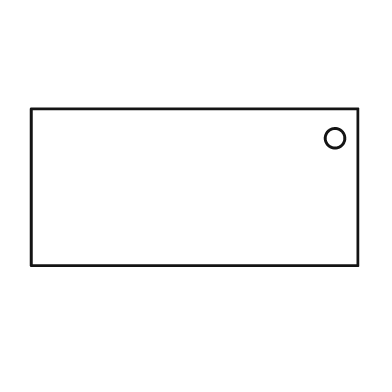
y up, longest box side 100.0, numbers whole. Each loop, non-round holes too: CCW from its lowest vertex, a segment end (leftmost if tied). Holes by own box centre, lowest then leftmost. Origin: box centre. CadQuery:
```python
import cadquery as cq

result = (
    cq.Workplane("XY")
    .moveTo(-50.0, -24.0)
    .lineTo(50.0, -24.0)
    .lineTo(50.0, 24.0)
    .lineTo(-50.0, 24.0)
    .close()
    .moveTo(43.0, 15.0)
    .circle(3.0)
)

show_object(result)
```